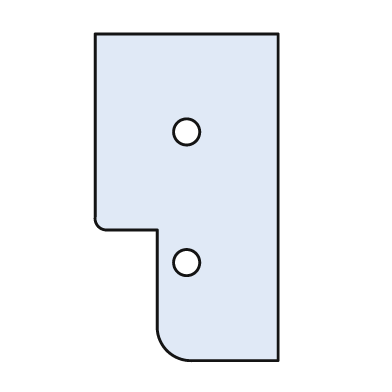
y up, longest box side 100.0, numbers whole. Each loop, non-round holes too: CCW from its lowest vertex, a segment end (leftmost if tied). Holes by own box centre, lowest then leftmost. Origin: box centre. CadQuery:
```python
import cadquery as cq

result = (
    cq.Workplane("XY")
    .moveTo(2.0, -50.0)
    .lineTo(28.0, -50.0)
    .lineTo(28.0, 50.0)
    .lineTo(-28.0, 50.0)
    .lineTo(-28.0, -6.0)
    .threePointArc((-27.0, -9.0), (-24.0, -10.0))
    .lineTo(-9.0, -10.0)
    .lineTo(-9.0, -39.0)
    .threePointArc((-6.0, -47.0), (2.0, -50.0))
    .close()
    .moveTo(0.0, -20.0)
    .circle(4.0)
    .moveTo(0.0, 20.0)
    .circle(4.0)
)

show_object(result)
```